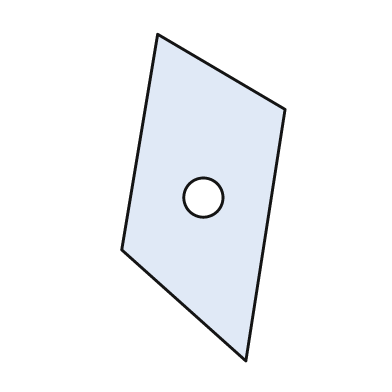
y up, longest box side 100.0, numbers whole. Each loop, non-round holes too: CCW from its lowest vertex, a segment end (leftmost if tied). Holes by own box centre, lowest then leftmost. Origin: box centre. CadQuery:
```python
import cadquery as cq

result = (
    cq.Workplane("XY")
    .moveTo(13.0, -50.0)
    .lineTo(25.0, 27.0)
    .lineTo(-14.0, 50.0)
    .lineTo(-25.0, -16.0)
    .close()
    .moveTo(0.0, 0.0)
    .circle(6.0)
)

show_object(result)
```